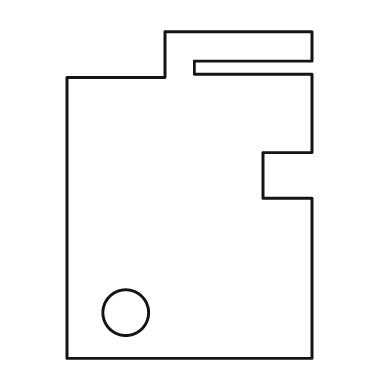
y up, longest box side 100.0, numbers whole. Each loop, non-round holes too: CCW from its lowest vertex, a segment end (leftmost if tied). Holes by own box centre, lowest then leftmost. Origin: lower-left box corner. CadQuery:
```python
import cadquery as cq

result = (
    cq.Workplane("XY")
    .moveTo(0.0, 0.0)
    .lineTo(75.0, 0.0)
    .lineTo(75.0, 49.0)
    .lineTo(60.0, 49.0)
    .lineTo(60.0, 63.0)
    .lineTo(75.0, 63.0)
    .lineTo(75.0, 87.0)
    .lineTo(39.0, 87.0)
    .lineTo(39.0, 91.0)
    .lineTo(75.0, 91.0)
    .lineTo(75.0, 100.0)
    .lineTo(30.0, 100.0)
    .lineTo(30.0, 86.0)
    .lineTo(0.0, 86.0)
    .close()
    .moveTo(18.0, 14.0)
    .circle(7.0)
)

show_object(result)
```